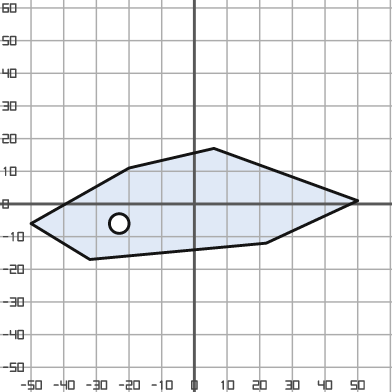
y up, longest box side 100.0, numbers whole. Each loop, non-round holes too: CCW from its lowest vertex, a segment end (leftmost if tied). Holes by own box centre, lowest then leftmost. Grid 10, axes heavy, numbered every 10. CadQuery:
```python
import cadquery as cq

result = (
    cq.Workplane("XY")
    .moveTo(-32.0, -17.0)
    .lineTo(22.0, -12.0)
    .lineTo(50.0, 1.0)
    .lineTo(6.0, 17.0)
    .lineTo(-20.0, 11.0)
    .lineTo(-50.0, -6.0)
    .close()
    .moveTo(-23.0, -6.0)
    .circle(3.0)
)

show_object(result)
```